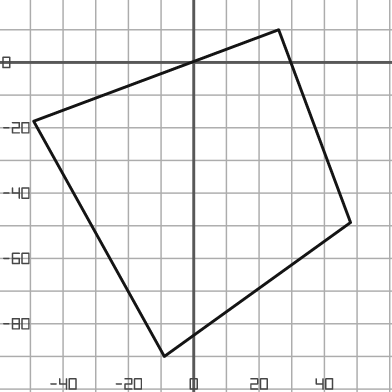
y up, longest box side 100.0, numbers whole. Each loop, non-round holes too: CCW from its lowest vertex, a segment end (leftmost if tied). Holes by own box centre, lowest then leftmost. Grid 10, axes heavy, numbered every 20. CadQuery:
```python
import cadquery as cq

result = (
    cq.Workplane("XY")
    .moveTo(-9.0, -90.0)
    .lineTo(48.0, -49.0)
    .lineTo(26.0, 10.0)
    .lineTo(-49.0, -18.0)
    .close()
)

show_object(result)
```